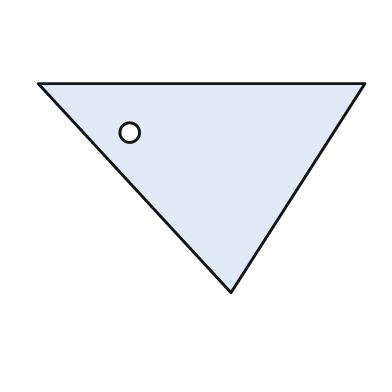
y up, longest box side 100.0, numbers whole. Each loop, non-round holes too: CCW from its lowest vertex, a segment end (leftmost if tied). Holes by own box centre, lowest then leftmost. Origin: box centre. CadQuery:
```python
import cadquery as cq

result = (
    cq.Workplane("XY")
    .moveTo(9.0, -32.0)
    .lineTo(50.0, 32.0)
    .lineTo(-50.0, 32.0)
    .close()
    .moveTo(-22.0, 17.0)
    .circle(3.0)
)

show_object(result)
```